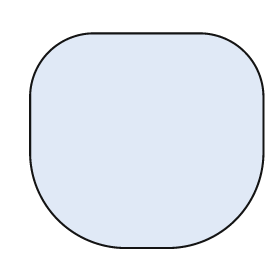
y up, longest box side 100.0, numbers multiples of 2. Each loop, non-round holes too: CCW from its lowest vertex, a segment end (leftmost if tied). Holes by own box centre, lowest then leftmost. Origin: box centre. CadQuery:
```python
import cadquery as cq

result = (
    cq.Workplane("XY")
    .moveTo(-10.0, -46.0)
    .lineTo(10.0, -46.0)
    .threePointArc((38.0, -34.0), (50.0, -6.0))
    .lineTo(50.0, 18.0)
    .threePointArc((42.0, 38.0), (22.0, 46.0))
    .lineTo(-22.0, 46.0)
    .threePointArc((-42.0, 38.0), (-50.0, 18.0))
    .lineTo(-50.0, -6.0)
    .threePointArc((-38.0, -34.0), (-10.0, -46.0))
    .close()
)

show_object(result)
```